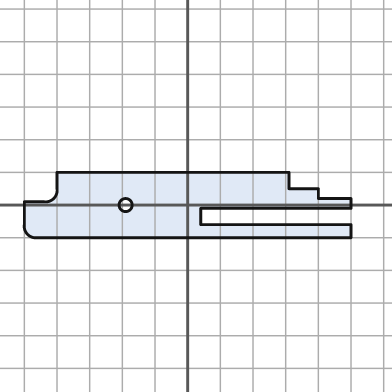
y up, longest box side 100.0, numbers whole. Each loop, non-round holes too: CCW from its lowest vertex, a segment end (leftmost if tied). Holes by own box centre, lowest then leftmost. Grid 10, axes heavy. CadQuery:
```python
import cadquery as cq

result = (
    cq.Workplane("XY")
    .moveTo(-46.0, -10.0)
    .lineTo(50.0, -10.0)
    .lineTo(50.0, -6.0)
    .lineTo(4.0, -6.0)
    .lineTo(4.0, -1.0)
    .lineTo(50.0, -1.0)
    .lineTo(50.0, 2.0)
    .lineTo(40.0, 2.0)
    .lineTo(40.0, 5.0)
    .lineTo(31.0, 5.0)
    .lineTo(31.0, 10.0)
    .lineTo(-40.0, 10.0)
    .lineTo(-40.0, 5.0)
    .threePointArc((-41.0, 2.0), (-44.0, 1.0))
    .lineTo(-50.0, 1.0)
    .lineTo(-50.0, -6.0)
    .threePointArc((-49.0, -9.0), (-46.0, -10.0))
    .close()
    .moveTo(-19.0, 0.0)
    .circle(2.0)
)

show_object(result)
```